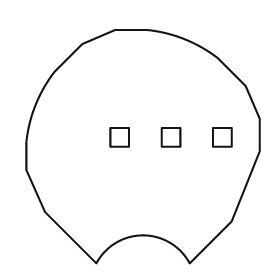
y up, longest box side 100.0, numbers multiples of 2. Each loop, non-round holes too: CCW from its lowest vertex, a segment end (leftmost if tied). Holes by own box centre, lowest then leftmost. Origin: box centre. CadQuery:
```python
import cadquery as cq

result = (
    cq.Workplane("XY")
    .moveTo(-20.0, -50.0)
    .threePointArc((0.0, -38.0), (20.0, -50.0))
    .lineTo(38.0, -32.0)
    .lineTo(50.0, -2.0)
    .lineTo(50.0, 12.0)
    .lineTo(44.0, 26.0)
    .lineTo(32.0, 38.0)
    .threePointArc((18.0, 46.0), (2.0, 50.0))
    .lineTo(-12.0, 50.0)
    .lineTo(-26.0, 44.0)
    .lineTo(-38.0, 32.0)
    .threePointArc((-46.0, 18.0), (-50.0, 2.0))
    .lineTo(-50.0, -10.0)
    .lineTo(-42.0, -28.0)
    .close()
    .moveTo(-14.0, 0.0)
    .lineTo(-6.0, 0.0)
    .lineTo(-6.0, 8.0)
    .lineTo(-14.0, 8.0)
    .close()
    .moveTo(8.0, 0.0)
    .lineTo(16.0, 0.0)
    .lineTo(16.0, 8.0)
    .lineTo(8.0, 8.0)
    .close()
    .moveTo(30.0, 0.0)
    .lineTo(38.0, 0.0)
    .lineTo(38.0, 8.0)
    .lineTo(30.0, 8.0)
    .close()
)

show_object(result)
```